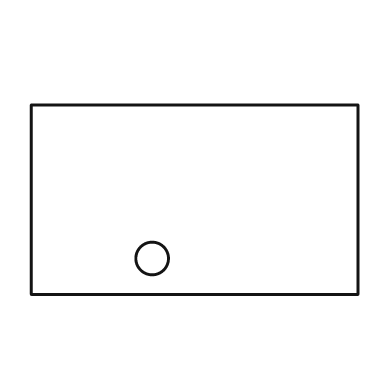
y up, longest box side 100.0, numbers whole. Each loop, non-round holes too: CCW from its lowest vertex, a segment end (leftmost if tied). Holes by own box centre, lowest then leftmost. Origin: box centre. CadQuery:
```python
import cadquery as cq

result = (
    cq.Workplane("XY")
    .moveTo(-50.0, -29.0)
    .lineTo(50.0, -29.0)
    .lineTo(50.0, 29.0)
    .lineTo(-50.0, 29.0)
    .close()
    .moveTo(-13.0, -18.0)
    .circle(5.0)
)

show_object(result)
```